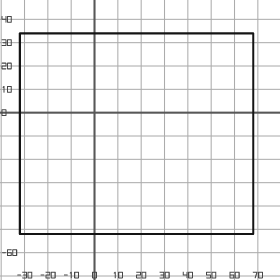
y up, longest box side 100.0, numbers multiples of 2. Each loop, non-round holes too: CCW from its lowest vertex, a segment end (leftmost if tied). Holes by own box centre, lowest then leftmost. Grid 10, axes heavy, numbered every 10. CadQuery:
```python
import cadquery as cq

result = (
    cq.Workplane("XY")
    .moveTo(-32.0, -52.0)
    .lineTo(68.0, -52.0)
    .lineTo(68.0, 34.0)
    .lineTo(-32.0, 34.0)
    .close()
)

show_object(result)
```